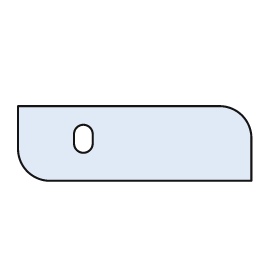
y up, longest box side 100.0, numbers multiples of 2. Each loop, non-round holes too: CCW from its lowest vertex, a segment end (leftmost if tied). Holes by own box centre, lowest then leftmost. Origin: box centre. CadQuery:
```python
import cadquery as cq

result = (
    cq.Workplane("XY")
    .moveTo(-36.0, -16.0)
    .lineTo(50.0, -16.0)
    .lineTo(50.0, 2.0)
    .threePointArc((46.0, 12.0), (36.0, 16.0))
    .lineTo(-50.0, 16.0)
    .lineTo(-50.0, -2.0)
    .threePointArc((-46.0, -12.0), (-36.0, -16.0))
    .close()
    .moveTo(-26.0, 0.0)
    .threePointArc((-22.0, -4.0), (-18.0, 0.0))
    .lineTo(-18.0, 4.0)
    .threePointArc((-22.0, 8.0), (-26.0, 4.0))
    .close()
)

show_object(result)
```